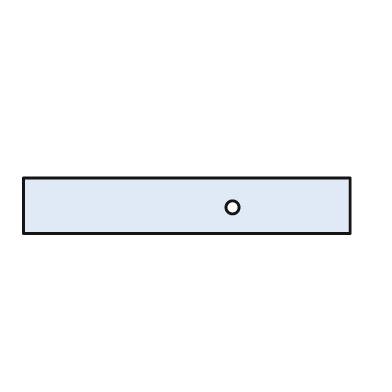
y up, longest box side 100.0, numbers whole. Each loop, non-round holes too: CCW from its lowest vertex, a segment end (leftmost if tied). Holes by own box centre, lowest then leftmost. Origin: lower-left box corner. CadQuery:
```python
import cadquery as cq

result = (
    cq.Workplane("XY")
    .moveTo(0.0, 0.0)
    .lineTo(100.0, 0.0)
    .lineTo(100.0, 17.0)
    .lineTo(0.0, 17.0)
    .close()
    .moveTo(64.0, 8.0)
    .circle(2.0)
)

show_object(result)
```